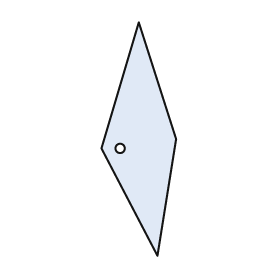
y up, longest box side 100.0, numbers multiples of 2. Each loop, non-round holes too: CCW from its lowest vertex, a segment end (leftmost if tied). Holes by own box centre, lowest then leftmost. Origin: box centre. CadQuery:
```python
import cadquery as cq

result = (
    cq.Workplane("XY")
    .moveTo(8.0, -50.0)
    .lineTo(16.0, 0.0)
    .lineTo(0.0, 50.0)
    .lineTo(-16.0, -4.0)
    .close()
    .moveTo(-8.0, -4.0)
    .circle(2.0)
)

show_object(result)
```